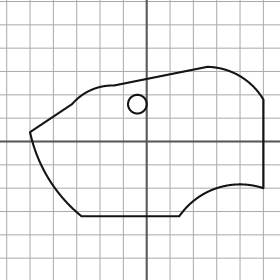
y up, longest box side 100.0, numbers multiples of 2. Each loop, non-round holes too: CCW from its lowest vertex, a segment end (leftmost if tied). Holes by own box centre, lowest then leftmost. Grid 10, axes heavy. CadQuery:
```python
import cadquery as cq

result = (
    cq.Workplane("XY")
    .moveTo(-28.0, -32.0)
    .lineTo(14.0, -32.0)
    .threePointArc((30.0, -20.0), (50.0, -20.0))
    .lineTo(50.0, 18.0)
    .threePointArc((40.0, 28.0), (26.0, 32.0))
    .lineTo(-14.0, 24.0)
    .threePointArc((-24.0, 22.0), (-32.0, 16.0))
    .lineTo(-50.0, 4.0)
    .threePointArc((-42.0, -16.0), (-28.0, -32.0))
    .close()
    .moveTo(-4.0, 16.0)
    .circle(4.0)
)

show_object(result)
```